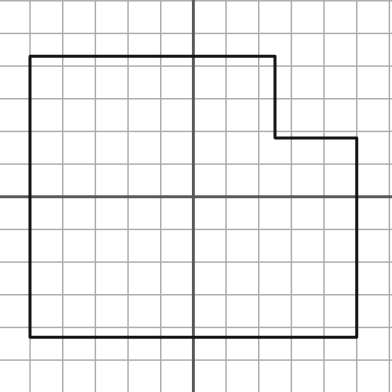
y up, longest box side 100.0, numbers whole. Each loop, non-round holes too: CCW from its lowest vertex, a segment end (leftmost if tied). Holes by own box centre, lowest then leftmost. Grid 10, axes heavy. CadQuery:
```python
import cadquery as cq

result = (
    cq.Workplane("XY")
    .moveTo(-50.0, -43.0)
    .lineTo(50.0, -43.0)
    .lineTo(50.0, 18.0)
    .lineTo(25.0, 18.0)
    .lineTo(25.0, 43.0)
    .lineTo(-50.0, 43.0)
    .close()
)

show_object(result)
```